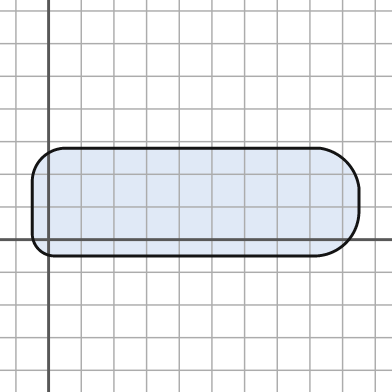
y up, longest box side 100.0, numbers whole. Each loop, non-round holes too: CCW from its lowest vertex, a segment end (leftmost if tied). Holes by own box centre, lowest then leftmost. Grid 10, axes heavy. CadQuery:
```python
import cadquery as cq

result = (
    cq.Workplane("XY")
    .moveTo(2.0, -5.0)
    .lineTo(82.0, -5.0)
    .threePointArc((91.0, -1.0), (95.0, 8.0))
    .lineTo(95.0, 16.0)
    .threePointArc((91.0, 24.0), (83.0, 28.0))
    .lineTo(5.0, 28.0)
    .threePointArc((-2.0, 25.0), (-5.0, 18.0))
    .lineTo(-5.0, 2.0)
    .threePointArc((-3.0, -3.0), (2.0, -5.0))
    .close()
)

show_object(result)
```